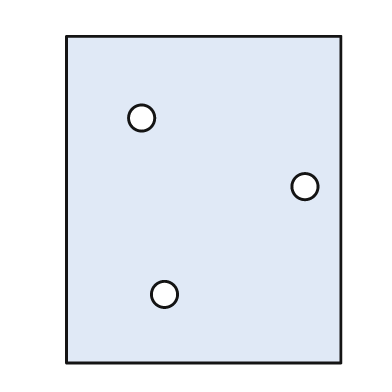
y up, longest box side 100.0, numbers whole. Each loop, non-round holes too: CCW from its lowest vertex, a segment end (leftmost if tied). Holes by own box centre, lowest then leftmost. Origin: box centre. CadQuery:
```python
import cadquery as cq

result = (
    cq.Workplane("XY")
    .moveTo(-42.0, -50.0)
    .lineTo(42.0, -50.0)
    .lineTo(42.0, 50.0)
    .lineTo(-42.0, 50.0)
    .close()
    .moveTo(-12.0, -29.0)
    .circle(4.0)
    .moveTo(31.0, 4.0)
    .circle(4.0)
    .moveTo(-19.0, 25.0)
    .circle(4.0)
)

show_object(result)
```